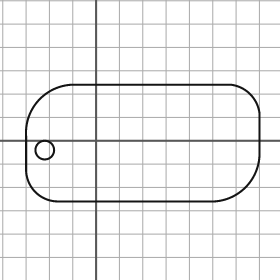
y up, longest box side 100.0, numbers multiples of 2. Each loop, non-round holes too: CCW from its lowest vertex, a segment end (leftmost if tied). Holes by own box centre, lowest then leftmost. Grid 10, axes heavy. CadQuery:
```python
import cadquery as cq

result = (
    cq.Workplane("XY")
    .moveTo(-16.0, -26.0)
    .lineTo(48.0, -26.0)
    .threePointArc((64.0, -20.0), (70.0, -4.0))
    .lineTo(70.0, 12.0)
    .threePointArc((66.0, 20.0), (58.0, 24.0))
    .lineTo(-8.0, 24.0)
    .threePointArc((-24.0, 18.0), (-30.0, 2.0))
    .lineTo(-30.0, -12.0)
    .threePointArc((-26.0, -22.0), (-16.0, -26.0))
    .close()
    .moveTo(-22.0, -4.0)
    .circle(4.0)
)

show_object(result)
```